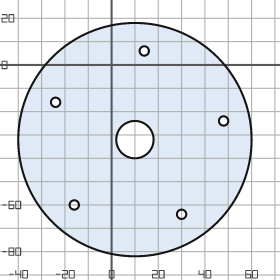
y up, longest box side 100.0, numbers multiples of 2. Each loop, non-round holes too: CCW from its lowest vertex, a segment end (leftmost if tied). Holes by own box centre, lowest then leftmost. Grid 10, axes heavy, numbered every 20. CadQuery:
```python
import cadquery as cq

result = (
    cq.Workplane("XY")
    .moveTo(10.0, -32.0)
    .circle(50.0)
    .moveTo(30.0, -64.0)
    .circle(2.0)
    .moveTo(-16.0, -60.0)
    .circle(2.0)
    .moveTo(10.0, -32.0)
    .circle(8.0)
    .moveTo(48.0, -24.0)
    .circle(2.0)
    .moveTo(-24.0, -16.0)
    .circle(2.0)
    .moveTo(14.0, 6.0)
    .circle(2.0)
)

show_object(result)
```